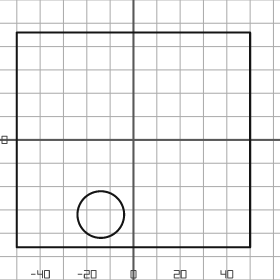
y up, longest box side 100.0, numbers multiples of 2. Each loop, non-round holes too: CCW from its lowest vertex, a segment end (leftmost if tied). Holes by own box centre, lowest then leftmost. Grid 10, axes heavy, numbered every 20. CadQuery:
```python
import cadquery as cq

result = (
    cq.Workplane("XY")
    .moveTo(-50.0, -46.0)
    .lineTo(50.0, -46.0)
    .lineTo(50.0, 46.0)
    .lineTo(-50.0, 46.0)
    .close()
    .moveTo(-14.0, -32.0)
    .circle(10.0)
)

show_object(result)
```